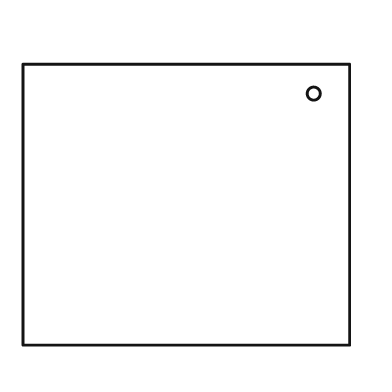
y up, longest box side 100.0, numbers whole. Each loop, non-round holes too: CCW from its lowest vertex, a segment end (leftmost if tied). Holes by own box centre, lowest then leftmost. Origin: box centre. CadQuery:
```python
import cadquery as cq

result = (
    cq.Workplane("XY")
    .moveTo(-50.0, -43.0)
    .lineTo(50.0, -43.0)
    .lineTo(50.0, 43.0)
    .lineTo(-50.0, 43.0)
    .close()
    .moveTo(39.0, 34.0)
    .circle(2.0)
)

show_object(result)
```